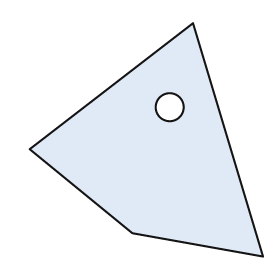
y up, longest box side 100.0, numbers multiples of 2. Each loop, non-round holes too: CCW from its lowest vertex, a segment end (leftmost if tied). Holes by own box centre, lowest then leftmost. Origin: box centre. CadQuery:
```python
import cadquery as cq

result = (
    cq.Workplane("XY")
    .moveTo(50.0, -50.0)
    .lineTo(20.0, 50.0)
    .lineTo(-50.0, -4.0)
    .lineTo(-6.0, -40.0)
    .close()
    .moveTo(10.0, 14.0)
    .circle(6.0)
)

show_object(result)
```